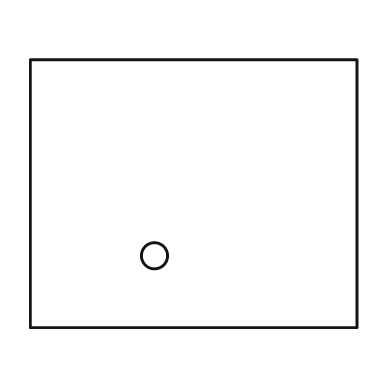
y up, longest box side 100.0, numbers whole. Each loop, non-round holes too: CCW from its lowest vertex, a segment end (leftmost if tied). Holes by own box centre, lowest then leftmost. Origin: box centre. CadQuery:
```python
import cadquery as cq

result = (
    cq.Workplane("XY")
    .moveTo(-50.0, -41.0)
    .lineTo(50.0, -41.0)
    .lineTo(50.0, 41.0)
    .lineTo(-50.0, 41.0)
    .close()
    .moveTo(-12.0, -19.0)
    .circle(4.0)
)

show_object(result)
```